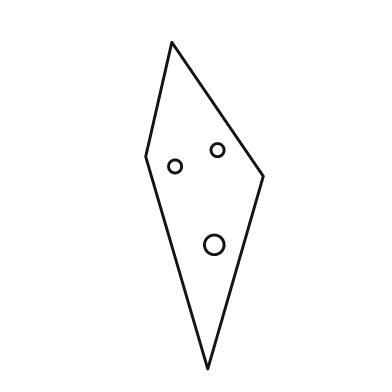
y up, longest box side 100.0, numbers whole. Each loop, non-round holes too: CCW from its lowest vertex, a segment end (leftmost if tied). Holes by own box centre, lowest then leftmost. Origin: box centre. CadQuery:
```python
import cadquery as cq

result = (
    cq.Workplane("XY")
    .moveTo(1.0, -50.0)
    .lineTo(18.0, 9.0)
    .lineTo(-10.0, 50.0)
    .lineTo(-18.0, 15.0)
    .close()
    .moveTo(3.0, -12.0)
    .circle(3.0)
    .moveTo(-9.0, 12.0)
    .circle(2.0)
    .moveTo(4.0, 17.0)
    .circle(2.0)
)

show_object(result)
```